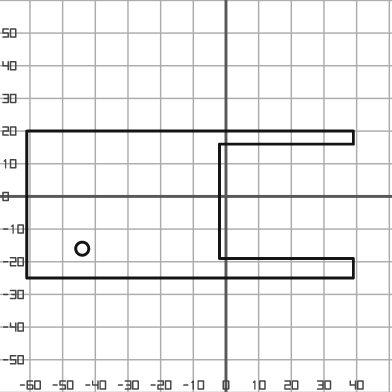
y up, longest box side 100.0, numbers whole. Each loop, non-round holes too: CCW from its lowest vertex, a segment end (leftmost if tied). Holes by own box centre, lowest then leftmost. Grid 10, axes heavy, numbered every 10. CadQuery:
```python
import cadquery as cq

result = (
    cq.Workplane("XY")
    .moveTo(-61.0, -25.0)
    .lineTo(39.0, -25.0)
    .lineTo(39.0, -19.0)
    .lineTo(-2.0, -19.0)
    .lineTo(-2.0, 16.0)
    .lineTo(39.0, 16.0)
    .lineTo(39.0, 20.0)
    .lineTo(-61.0, 20.0)
    .close()
    .moveTo(-44.0, -16.0)
    .circle(2.0)
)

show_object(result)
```